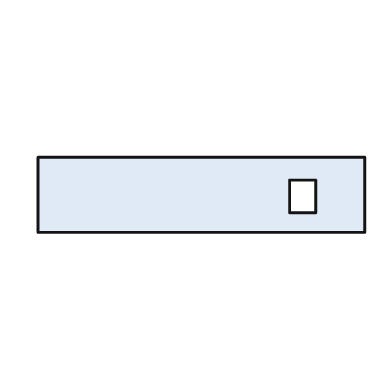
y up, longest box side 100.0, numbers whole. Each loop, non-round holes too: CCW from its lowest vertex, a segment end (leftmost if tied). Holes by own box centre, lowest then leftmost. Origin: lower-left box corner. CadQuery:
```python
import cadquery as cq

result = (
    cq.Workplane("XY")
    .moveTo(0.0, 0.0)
    .lineTo(100.0, 0.0)
    .lineTo(100.0, 23.0)
    .lineTo(0.0, 23.0)
    .close()
    .moveTo(77.0, 6.0)
    .lineTo(85.0, 6.0)
    .lineTo(85.0, 16.0)
    .lineTo(77.0, 16.0)
    .close()
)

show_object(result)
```